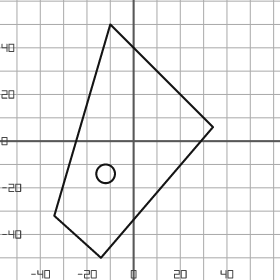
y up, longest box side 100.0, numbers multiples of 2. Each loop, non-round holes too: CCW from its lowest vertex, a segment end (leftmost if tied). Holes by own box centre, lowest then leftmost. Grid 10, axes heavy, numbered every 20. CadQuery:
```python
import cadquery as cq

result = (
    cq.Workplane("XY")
    .moveTo(-14.0, -50.0)
    .lineTo(34.0, 6.0)
    .lineTo(-10.0, 50.0)
    .lineTo(-34.0, -32.0)
    .close()
    .moveTo(-12.0, -14.0)
    .circle(4.0)
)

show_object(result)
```